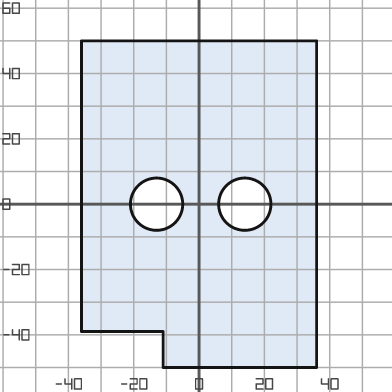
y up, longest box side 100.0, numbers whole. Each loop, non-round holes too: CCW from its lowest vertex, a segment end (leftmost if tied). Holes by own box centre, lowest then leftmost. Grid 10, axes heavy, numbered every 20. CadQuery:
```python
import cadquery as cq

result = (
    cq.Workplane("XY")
    .moveTo(-11.0, -50.0)
    .lineTo(36.0, -50.0)
    .lineTo(36.0, 50.0)
    .lineTo(-36.0, 50.0)
    .lineTo(-36.0, -39.0)
    .lineTo(-11.0, -39.0)
    .close()
    .moveTo(-13.0, 0.0)
    .circle(8.0)
    .moveTo(14.0, 0.0)
    .circle(8.0)
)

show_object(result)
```